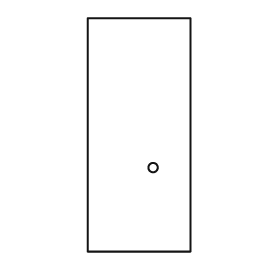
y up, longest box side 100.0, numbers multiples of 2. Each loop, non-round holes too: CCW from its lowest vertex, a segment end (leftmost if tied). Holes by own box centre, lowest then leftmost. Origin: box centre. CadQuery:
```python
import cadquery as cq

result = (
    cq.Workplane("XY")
    .moveTo(-22.0, -50.0)
    .lineTo(22.0, -50.0)
    .lineTo(22.0, 50.0)
    .lineTo(-22.0, 50.0)
    .close()
    .moveTo(6.0, -14.0)
    .circle(2.0)
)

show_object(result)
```